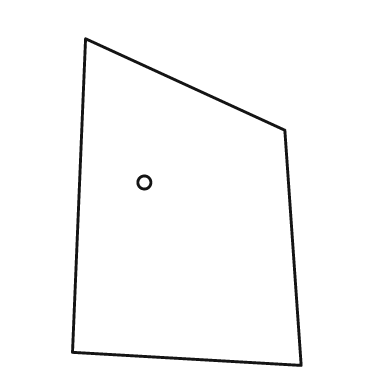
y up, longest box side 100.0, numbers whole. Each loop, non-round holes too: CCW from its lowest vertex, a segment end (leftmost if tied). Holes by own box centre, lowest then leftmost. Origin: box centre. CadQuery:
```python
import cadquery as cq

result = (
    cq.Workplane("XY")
    .moveTo(35.0, -50.0)
    .lineTo(30.0, 22.0)
    .lineTo(-31.0, 50.0)
    .lineTo(-35.0, -46.0)
    .close()
    .moveTo(-13.0, 6.0)
    .circle(2.0)
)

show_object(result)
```